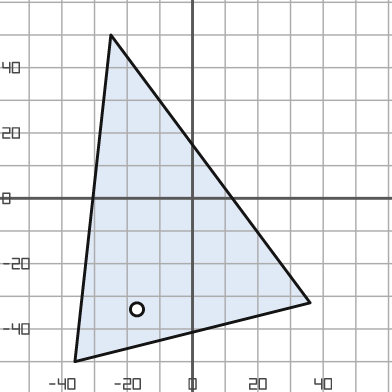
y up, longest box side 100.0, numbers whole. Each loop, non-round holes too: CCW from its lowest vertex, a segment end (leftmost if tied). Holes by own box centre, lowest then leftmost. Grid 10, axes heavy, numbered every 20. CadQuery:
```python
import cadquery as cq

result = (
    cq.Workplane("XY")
    .moveTo(-36.0, -50.0)
    .lineTo(36.0, -32.0)
    .lineTo(-25.0, 50.0)
    .close()
    .moveTo(-17.0, -34.0)
    .circle(2.0)
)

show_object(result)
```